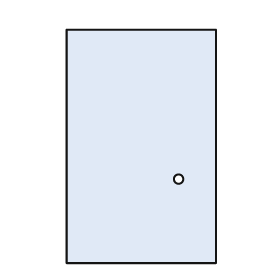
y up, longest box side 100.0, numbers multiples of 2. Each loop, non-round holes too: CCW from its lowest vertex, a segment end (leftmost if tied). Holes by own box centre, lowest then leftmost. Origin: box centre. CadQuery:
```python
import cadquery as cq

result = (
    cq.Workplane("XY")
    .moveTo(-32.0, -50.0)
    .lineTo(32.0, -50.0)
    .lineTo(32.0, 50.0)
    .lineTo(-32.0, 50.0)
    .close()
    .moveTo(16.0, -14.0)
    .circle(2.0)
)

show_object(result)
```